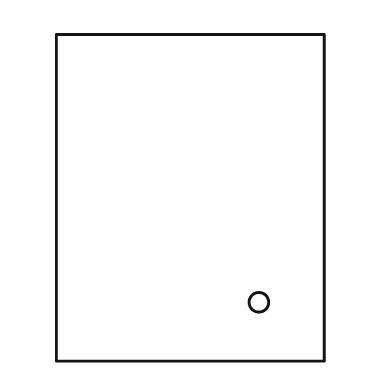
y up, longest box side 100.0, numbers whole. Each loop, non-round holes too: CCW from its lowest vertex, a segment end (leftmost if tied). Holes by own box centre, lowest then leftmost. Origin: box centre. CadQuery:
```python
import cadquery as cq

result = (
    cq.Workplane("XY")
    .moveTo(-41.0, -50.0)
    .lineTo(41.0, -50.0)
    .lineTo(41.0, 50.0)
    .lineTo(-41.0, 50.0)
    .close()
    .moveTo(21.0, -32.0)
    .circle(3.0)
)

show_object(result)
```